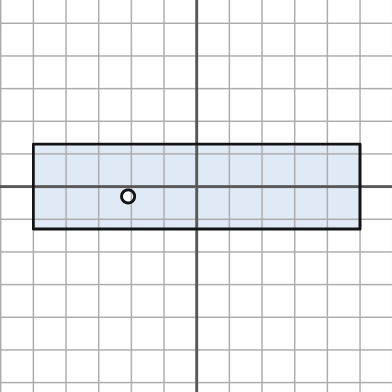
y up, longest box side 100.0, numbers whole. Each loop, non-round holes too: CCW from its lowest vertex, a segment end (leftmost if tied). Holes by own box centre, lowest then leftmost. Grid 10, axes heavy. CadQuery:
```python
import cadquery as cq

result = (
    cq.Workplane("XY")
    .moveTo(-50.0, -13.0)
    .lineTo(50.0, -13.0)
    .lineTo(50.0, 13.0)
    .lineTo(-50.0, 13.0)
    .close()
    .moveTo(-21.0, -3.0)
    .circle(2.0)
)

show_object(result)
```